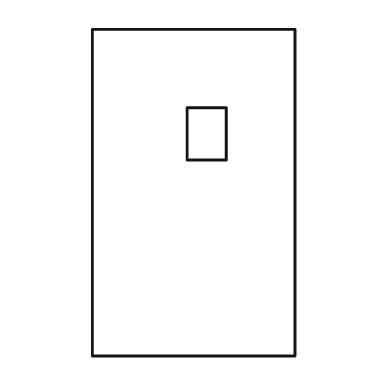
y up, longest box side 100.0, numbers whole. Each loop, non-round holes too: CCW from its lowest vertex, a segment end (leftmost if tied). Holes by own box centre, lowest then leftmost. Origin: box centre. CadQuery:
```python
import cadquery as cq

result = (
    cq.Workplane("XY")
    .moveTo(-31.0, -50.0)
    .lineTo(31.0, -50.0)
    .lineTo(31.0, 50.0)
    .lineTo(-31.0, 50.0)
    .close()
    .moveTo(-2.0, 10.0)
    .lineTo(10.0, 10.0)
    .lineTo(10.0, 26.0)
    .lineTo(-2.0, 26.0)
    .close()
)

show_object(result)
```